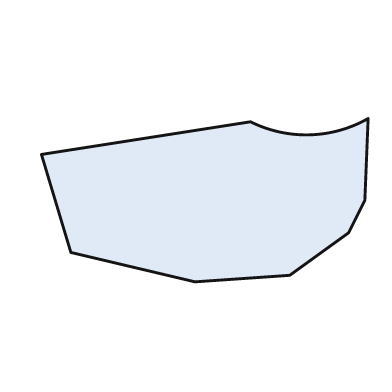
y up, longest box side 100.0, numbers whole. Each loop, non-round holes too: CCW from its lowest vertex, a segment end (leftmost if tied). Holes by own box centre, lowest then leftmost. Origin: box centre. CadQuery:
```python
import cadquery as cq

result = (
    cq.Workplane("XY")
    .moveTo(-3.0, -25.0)
    .lineTo(26.0, -23.0)
    .lineTo(44.0, -10.0)
    .lineTo(49.0, 0.0)
    .lineTo(50.0, 25.0)
    .threePointArc((32.0, 20.0), (14.0, 24.0))
    .lineTo(-50.0, 14.0)
    .lineTo(-41.0, -16.0)
    .close()
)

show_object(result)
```